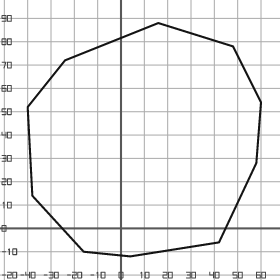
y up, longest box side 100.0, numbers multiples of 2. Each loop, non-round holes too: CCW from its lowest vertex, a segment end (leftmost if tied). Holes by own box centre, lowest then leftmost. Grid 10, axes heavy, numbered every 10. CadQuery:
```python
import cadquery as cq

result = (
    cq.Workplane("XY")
    .moveTo(4.0, -12.0)
    .lineTo(42.0, -6.0)
    .lineTo(58.0, 28.0)
    .lineTo(60.0, 54.0)
    .lineTo(48.0, 78.0)
    .lineTo(16.0, 88.0)
    .lineTo(-24.0, 72.0)
    .lineTo(-40.0, 52.0)
    .lineTo(-38.0, 14.0)
    .lineTo(-16.0, -10.0)
    .close()
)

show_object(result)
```